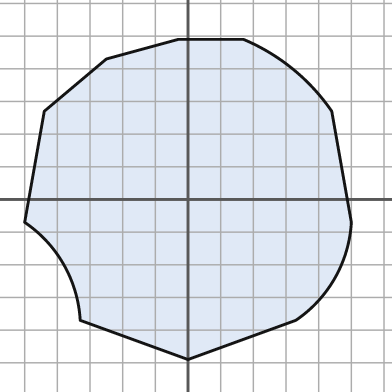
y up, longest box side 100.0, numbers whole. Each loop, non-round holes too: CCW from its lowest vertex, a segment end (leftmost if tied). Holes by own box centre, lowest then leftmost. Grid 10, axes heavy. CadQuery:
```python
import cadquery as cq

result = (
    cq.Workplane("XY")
    .moveTo(0.0, -49.0)
    .lineTo(33.0, -37.0)
    .threePointArc((45.0, -24.0), (50.0, -7.0))
    .lineTo(44.0, 27.0)
    .threePointArc((32.0, 40.0), (17.0, 49.0))
    .lineTo(-3.0, 49.0)
    .lineTo(-25.0, 43.0)
    .lineTo(-44.0, 27.0)
    .lineTo(-50.0, -7.0)
    .threePointArc((-38.0, -20.0), (-33.0, -37.0))
    .close()
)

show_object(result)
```